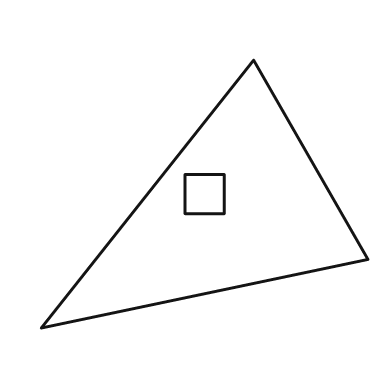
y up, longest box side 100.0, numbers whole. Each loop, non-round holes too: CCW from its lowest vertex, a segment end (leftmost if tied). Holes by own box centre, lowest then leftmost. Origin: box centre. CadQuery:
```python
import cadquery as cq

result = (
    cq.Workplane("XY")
    .moveTo(-50.0, -41.0)
    .lineTo(50.0, -20.0)
    .lineTo(15.0, 41.0)
    .close()
    .moveTo(-6.0, -6.0)
    .lineTo(6.0, -6.0)
    .lineTo(6.0, 6.0)
    .lineTo(-6.0, 6.0)
    .close()
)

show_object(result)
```